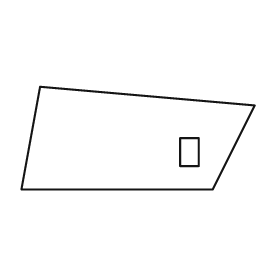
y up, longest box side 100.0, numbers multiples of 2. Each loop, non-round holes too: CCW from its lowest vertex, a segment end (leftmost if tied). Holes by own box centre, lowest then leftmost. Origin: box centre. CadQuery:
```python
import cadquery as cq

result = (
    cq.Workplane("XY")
    .moveTo(-50.0, -22.0)
    .lineTo(32.0, -22.0)
    .lineTo(50.0, 14.0)
    .lineTo(-42.0, 22.0)
    .close()
    .moveTo(18.0, -12.0)
    .lineTo(26.0, -12.0)
    .lineTo(26.0, 0.0)
    .lineTo(18.0, 0.0)
    .close()
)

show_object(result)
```